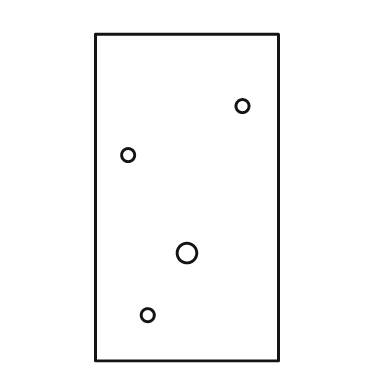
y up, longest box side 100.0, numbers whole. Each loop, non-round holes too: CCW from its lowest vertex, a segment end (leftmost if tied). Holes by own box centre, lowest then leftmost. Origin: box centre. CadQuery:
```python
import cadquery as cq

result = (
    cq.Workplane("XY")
    .moveTo(-28.0, -50.0)
    .lineTo(28.0, -50.0)
    .lineTo(28.0, 50.0)
    .lineTo(-28.0, 50.0)
    .close()
    .moveTo(-12.0, -36.0)
    .circle(2.0)
    .moveTo(0.0, -17.0)
    .circle(3.0)
    .moveTo(-18.0, 13.0)
    .circle(2.0)
    .moveTo(17.0, 28.0)
    .circle(2.0)
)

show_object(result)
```